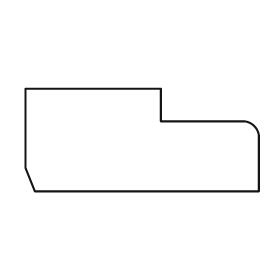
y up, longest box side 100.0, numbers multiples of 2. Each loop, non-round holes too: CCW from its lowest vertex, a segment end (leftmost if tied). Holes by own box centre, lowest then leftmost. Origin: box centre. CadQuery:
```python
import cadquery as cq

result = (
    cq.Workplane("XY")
    .moveTo(-46.0, -22.0)
    .lineTo(50.0, -22.0)
    .lineTo(50.0, 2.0)
    .threePointArc((48.0, 6.0), (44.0, 8.0))
    .lineTo(8.0, 8.0)
    .lineTo(8.0, 22.0)
    .lineTo(-50.0, 22.0)
    .lineTo(-50.0, -12.0)
    .close()
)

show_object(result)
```